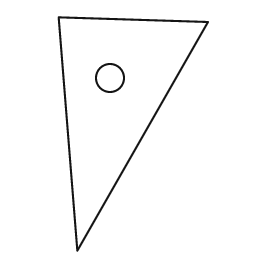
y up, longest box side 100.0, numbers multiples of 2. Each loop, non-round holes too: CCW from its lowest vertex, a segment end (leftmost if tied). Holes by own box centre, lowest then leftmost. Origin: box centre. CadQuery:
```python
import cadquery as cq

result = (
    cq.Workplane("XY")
    .moveTo(-24.0, -50.0)
    .lineTo(32.0, 48.0)
    .lineTo(-32.0, 50.0)
    .close()
    .moveTo(-10.0, 24.0)
    .circle(6.0)
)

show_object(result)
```